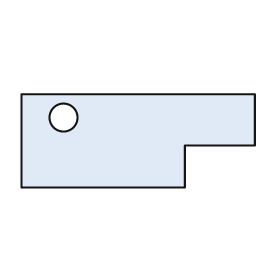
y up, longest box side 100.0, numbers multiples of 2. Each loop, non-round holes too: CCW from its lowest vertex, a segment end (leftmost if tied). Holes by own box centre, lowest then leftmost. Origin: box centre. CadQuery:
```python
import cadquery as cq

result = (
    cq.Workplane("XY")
    .moveTo(-50.0, -20.0)
    .lineTo(20.0, -20.0)
    .lineTo(20.0, -2.0)
    .lineTo(50.0, -2.0)
    .lineTo(50.0, 20.0)
    .lineTo(-50.0, 20.0)
    .close()
    .moveTo(-32.0, 10.0)
    .circle(6.0)
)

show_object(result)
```